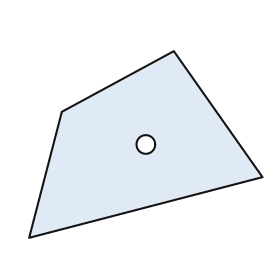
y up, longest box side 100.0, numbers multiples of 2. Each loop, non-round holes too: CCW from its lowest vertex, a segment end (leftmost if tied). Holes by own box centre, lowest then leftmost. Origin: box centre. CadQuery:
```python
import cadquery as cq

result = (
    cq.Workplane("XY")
    .moveTo(-50.0, -40.0)
    .lineTo(50.0, -14.0)
    .lineTo(12.0, 40.0)
    .lineTo(-36.0, 14.0)
    .close()
    .moveTo(0.0, 0.0)
    .circle(4.0)
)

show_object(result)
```